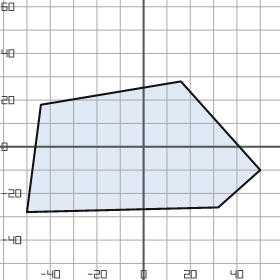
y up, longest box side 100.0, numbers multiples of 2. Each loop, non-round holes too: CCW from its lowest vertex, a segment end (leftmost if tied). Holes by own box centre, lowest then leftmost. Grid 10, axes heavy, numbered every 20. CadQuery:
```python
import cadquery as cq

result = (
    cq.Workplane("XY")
    .moveTo(-50.0, -28.0)
    .lineTo(32.0, -26.0)
    .lineTo(50.0, -10.0)
    .lineTo(16.0, 28.0)
    .lineTo(-44.0, 18.0)
    .close()
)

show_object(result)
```